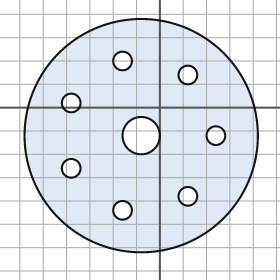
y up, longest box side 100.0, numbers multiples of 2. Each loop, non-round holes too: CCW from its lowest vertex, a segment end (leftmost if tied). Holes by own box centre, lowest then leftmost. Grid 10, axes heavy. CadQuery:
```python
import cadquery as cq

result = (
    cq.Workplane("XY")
    .moveTo(-8.0, -12.0)
    .circle(50.0)
    .moveTo(-16.0, -44.0)
    .circle(4.0)
    .moveTo(12.0, -38.0)
    .circle(4.0)
    .moveTo(-38.0, -26.0)
    .circle(4.0)
    .moveTo(-8.0, -12.0)
    .circle(8.0)
    .moveTo(24.0, -12.0)
    .circle(4.0)
    .moveTo(-38.0, 2.0)
    .circle(4.0)
    .moveTo(12.0, 14.0)
    .circle(4.0)
    .moveTo(-16.0, 20.0)
    .circle(4.0)
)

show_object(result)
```